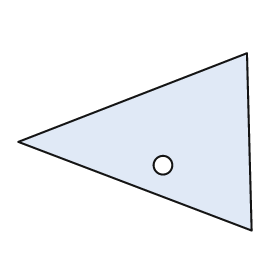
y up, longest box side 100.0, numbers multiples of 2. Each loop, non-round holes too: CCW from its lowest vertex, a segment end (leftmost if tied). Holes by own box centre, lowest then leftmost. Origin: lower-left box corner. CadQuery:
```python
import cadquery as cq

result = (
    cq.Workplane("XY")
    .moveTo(100.0, 0.0)
    .lineTo(98.0, 76.0)
    .lineTo(0.0, 38.0)
    .close()
    .moveTo(62.0, 28.0)
    .circle(4.0)
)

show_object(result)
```